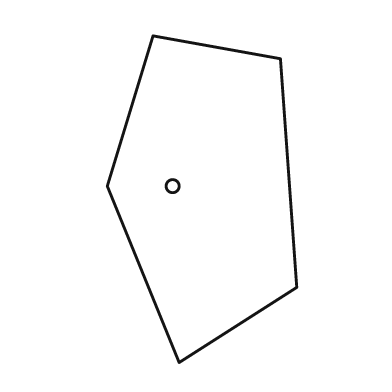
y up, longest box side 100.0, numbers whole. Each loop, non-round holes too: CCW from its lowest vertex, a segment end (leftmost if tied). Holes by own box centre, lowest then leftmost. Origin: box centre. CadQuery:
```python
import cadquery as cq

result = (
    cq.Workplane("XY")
    .moveTo(-7.0, -50.0)
    .lineTo(29.0, -27.0)
    .lineTo(24.0, 43.0)
    .lineTo(-15.0, 50.0)
    .lineTo(-29.0, 4.0)
    .close()
    .moveTo(-9.0, 4.0)
    .circle(2.0)
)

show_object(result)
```